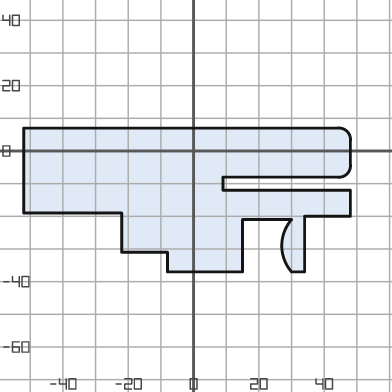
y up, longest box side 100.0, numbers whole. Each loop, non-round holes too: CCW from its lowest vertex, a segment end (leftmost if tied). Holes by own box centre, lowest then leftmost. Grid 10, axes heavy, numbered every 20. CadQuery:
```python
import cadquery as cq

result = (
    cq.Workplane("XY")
    .moveTo(-8.0, -37.0)
    .lineTo(15.0, -37.0)
    .lineTo(15.0, -21.0)
    .lineTo(30.0, -21.0)
    .threePointArc((27.0, -29.0), (30.0, -37.0))
    .lineTo(34.0, -37.0)
    .lineTo(34.0, -20.0)
    .lineTo(48.0, -20.0)
    .lineTo(48.0, -12.0)
    .lineTo(9.0, -12.0)
    .lineTo(9.0, -8.0)
    .lineTo(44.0, -8.0)
    .threePointArc((47.0, -7.0), (48.0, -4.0))
    .lineTo(48.0, 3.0)
    .threePointArc((47.0, 6.0), (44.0, 7.0))
    .lineTo(-52.0, 7.0)
    .lineTo(-52.0, -19.0)
    .lineTo(-22.0, -19.0)
    .lineTo(-22.0, -31.0)
    .lineTo(-8.0, -31.0)
    .close()
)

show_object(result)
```